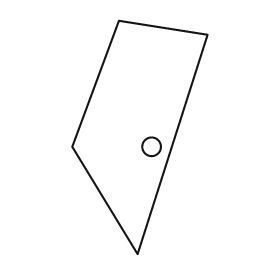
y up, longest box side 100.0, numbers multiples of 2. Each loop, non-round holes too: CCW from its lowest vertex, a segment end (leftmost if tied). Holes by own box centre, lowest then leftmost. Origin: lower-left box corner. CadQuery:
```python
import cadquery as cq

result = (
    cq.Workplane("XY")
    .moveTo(28.0, 0.0)
    .lineTo(58.0, 94.0)
    .lineTo(20.0, 100.0)
    .lineTo(0.0, 46.0)
    .close()
    .moveTo(34.0, 46.0)
    .circle(4.0)
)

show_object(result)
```